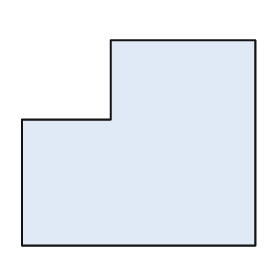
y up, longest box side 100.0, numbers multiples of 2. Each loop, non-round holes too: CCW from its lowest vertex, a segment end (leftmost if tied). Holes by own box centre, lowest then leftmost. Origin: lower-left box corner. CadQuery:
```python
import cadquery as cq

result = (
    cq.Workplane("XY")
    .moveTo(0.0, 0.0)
    .lineTo(100.0, 0.0)
    .lineTo(100.0, 88.0)
    .lineTo(38.0, 88.0)
    .lineTo(38.0, 54.0)
    .lineTo(0.0, 54.0)
    .close()
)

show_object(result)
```